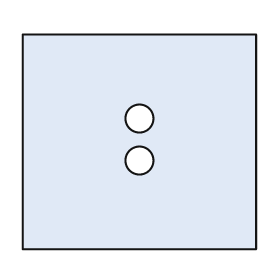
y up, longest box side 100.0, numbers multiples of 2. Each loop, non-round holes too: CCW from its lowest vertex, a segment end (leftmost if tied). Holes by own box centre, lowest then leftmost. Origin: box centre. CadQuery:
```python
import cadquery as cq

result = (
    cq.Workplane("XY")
    .moveTo(-50.0, -46.0)
    .lineTo(50.0, -46.0)
    .lineTo(50.0, 46.0)
    .lineTo(-50.0, 46.0)
    .close()
    .moveTo(0.0, -8.0)
    .circle(6.0)
    .moveTo(0.0, 10.0)
    .circle(6.0)
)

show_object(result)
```